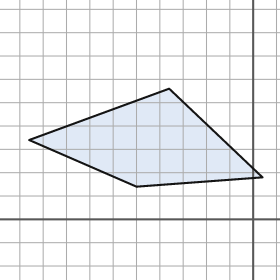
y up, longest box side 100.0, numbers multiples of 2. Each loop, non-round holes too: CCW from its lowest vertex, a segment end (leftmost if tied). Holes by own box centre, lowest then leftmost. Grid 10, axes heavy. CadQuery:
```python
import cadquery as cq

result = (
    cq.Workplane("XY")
    .moveTo(-50.0, 14.0)
    .lineTo(4.0, 18.0)
    .lineTo(-36.0, 56.0)
    .lineTo(-96.0, 34.0)
    .close()
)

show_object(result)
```